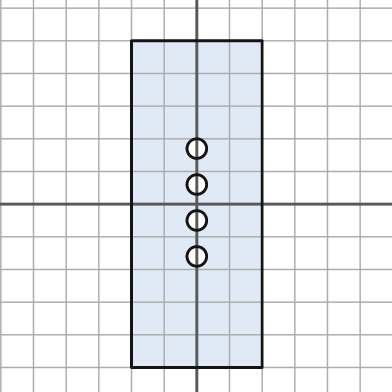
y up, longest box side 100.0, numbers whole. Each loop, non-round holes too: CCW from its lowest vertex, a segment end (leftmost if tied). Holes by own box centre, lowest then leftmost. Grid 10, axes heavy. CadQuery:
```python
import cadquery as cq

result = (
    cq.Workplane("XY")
    .moveTo(-20.0, -50.0)
    .lineTo(20.0, -50.0)
    .lineTo(20.0, 50.0)
    .lineTo(-20.0, 50.0)
    .close()
    .moveTo(0.0, -16.0)
    .circle(3.0)
    .moveTo(0.0, -5.0)
    .circle(3.0)
    .moveTo(0.0, 6.0)
    .circle(3.0)
    .moveTo(0.0, 17.0)
    .circle(3.0)
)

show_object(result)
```